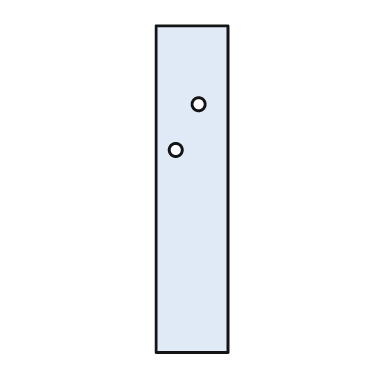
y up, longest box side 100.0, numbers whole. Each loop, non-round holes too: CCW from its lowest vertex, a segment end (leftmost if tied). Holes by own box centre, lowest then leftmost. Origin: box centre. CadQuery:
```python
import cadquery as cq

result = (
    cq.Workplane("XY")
    .moveTo(-11.0, -50.0)
    .lineTo(11.0, -50.0)
    .lineTo(11.0, 50.0)
    .lineTo(-11.0, 50.0)
    .close()
    .moveTo(-5.0, 12.0)
    .circle(2.0)
    .moveTo(2.0, 26.0)
    .circle(2.0)
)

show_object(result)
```